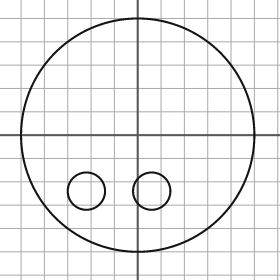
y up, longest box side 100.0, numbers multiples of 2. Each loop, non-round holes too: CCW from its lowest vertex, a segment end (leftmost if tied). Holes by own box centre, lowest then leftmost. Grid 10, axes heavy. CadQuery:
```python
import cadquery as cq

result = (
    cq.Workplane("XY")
    .moveTo(0.0, 0.0)
    .circle(50.0)
    .moveTo(-22.0, -24.0)
    .circle(8.0)
    .moveTo(6.0, -24.0)
    .circle(8.0)
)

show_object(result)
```